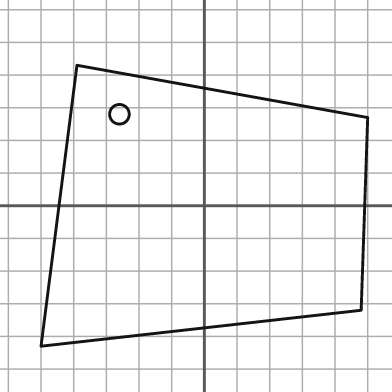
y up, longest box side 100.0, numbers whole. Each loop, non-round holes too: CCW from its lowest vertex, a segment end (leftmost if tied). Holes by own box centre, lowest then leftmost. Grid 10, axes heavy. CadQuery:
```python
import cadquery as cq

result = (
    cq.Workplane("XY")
    .moveTo(-50.0, -43.0)
    .lineTo(48.0, -32.0)
    .lineTo(50.0, 27.0)
    .lineTo(-39.0, 43.0)
    .close()
    .moveTo(-26.0, 28.0)
    .circle(3.0)
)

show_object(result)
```